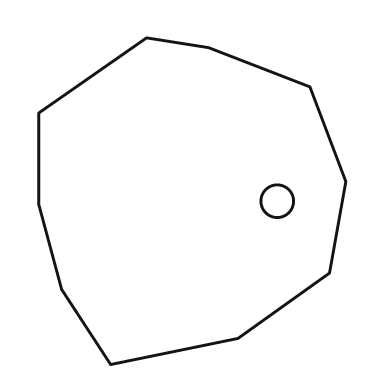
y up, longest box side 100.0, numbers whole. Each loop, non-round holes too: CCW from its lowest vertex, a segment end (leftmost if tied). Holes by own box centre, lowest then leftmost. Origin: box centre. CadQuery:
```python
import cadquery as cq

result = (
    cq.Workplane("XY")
    .moveTo(-25.0, -50.0)
    .lineTo(14.0, -42.0)
    .lineTo(42.0, -22.0)
    .lineTo(47.0, 6.0)
    .lineTo(36.0, 35.0)
    .lineTo(5.0, 47.0)
    .lineTo(-14.0, 50.0)
    .lineTo(-47.0, 27.0)
    .lineTo(-47.0, -1.0)
    .lineTo(-40.0, -27.0)
    .close()
    .moveTo(26.0, 0.0)
    .circle(5.0)
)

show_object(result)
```